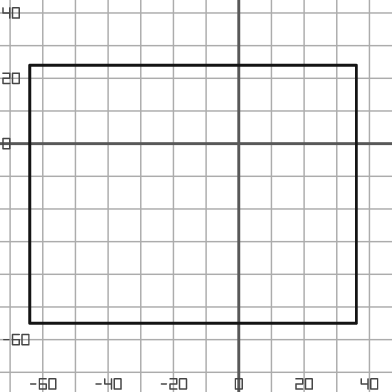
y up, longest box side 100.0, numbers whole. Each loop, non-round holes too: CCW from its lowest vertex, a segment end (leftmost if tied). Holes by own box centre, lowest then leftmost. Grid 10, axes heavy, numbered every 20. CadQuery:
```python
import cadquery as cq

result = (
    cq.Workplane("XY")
    .moveTo(-64.0, -55.0)
    .lineTo(36.0, -55.0)
    .lineTo(36.0, 24.0)
    .lineTo(-64.0, 24.0)
    .close()
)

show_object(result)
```